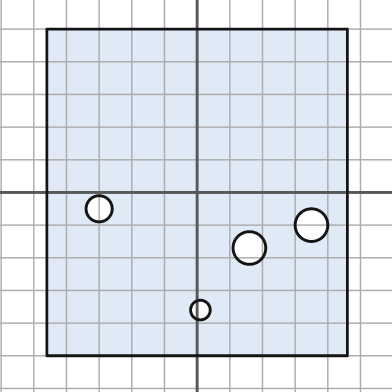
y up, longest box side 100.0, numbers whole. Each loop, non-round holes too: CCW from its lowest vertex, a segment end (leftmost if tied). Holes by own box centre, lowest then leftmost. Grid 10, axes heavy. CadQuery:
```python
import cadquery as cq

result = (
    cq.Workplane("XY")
    .moveTo(-46.0, -50.0)
    .lineTo(46.0, -50.0)
    .lineTo(46.0, 50.0)
    .lineTo(-46.0, 50.0)
    .close()
    .moveTo(1.0, -36.0)
    .circle(3.0)
    .moveTo(16.0, -17.0)
    .circle(5.0)
    .moveTo(35.0, -10.0)
    .circle(5.0)
    .moveTo(-30.0, -5.0)
    .circle(4.0)
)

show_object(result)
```